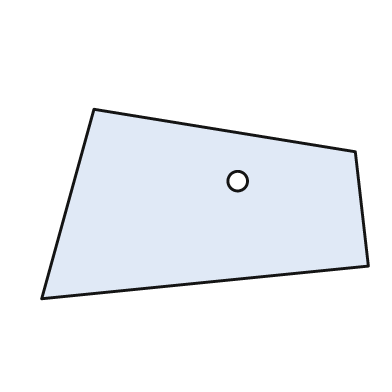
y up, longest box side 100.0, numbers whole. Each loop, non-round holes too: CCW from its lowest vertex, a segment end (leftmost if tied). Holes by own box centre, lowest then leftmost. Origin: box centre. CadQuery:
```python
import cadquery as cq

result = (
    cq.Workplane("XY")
    .moveTo(-50.0, -29.0)
    .lineTo(50.0, -19.0)
    .lineTo(46.0, 16.0)
    .lineTo(-34.0, 29.0)
    .close()
    .moveTo(10.0, 7.0)
    .circle(3.0)
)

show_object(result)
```